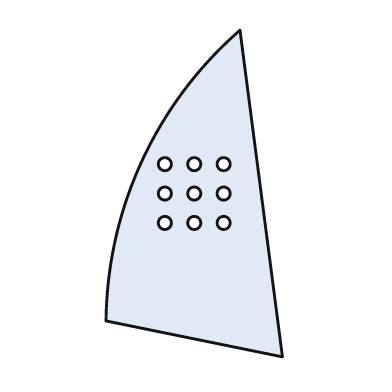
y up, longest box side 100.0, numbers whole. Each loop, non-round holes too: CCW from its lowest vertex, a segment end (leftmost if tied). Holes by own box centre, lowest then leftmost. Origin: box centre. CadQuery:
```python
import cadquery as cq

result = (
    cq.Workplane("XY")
    .moveTo(27.0, -50.0)
    .lineTo(14.0, 50.0)
    .threePointArc((-16.0, 10.0), (-27.0, -39.0))
    .close()
    .moveTo(-9.0, -9.0)
    .circle(2.0)
    .moveTo(0.0, -9.0)
    .circle(2.0)
    .moveTo(9.0, -9.0)
    .circle(2.0)
    .moveTo(-9.0, 0.0)
    .circle(2.0)
    .moveTo(0.0, 0.0)
    .circle(2.0)
    .moveTo(9.0, 0.0)
    .circle(2.0)
    .moveTo(-9.0, 9.0)
    .circle(2.0)
    .moveTo(0.0, 9.0)
    .circle(2.0)
    .moveTo(9.0, 9.0)
    .circle(2.0)
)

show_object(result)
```